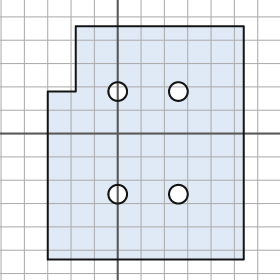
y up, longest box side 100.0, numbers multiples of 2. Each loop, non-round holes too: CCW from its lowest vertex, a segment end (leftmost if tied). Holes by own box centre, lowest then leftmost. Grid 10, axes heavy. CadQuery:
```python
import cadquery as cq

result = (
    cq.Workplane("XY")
    .moveTo(-30.0, -54.0)
    .lineTo(54.0, -54.0)
    .lineTo(54.0, 46.0)
    .lineTo(-18.0, 46.0)
    .lineTo(-18.0, 18.0)
    .lineTo(-30.0, 18.0)
    .close()
    .moveTo(0.0, -26.0)
    .circle(4.0)
    .moveTo(26.0, -26.0)
    .circle(4.0)
    .moveTo(0.0, 18.0)
    .circle(4.0)
    .moveTo(26.0, 18.0)
    .circle(4.0)
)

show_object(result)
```